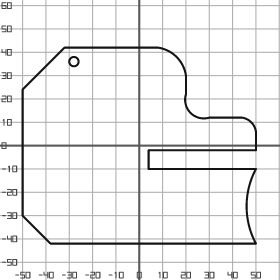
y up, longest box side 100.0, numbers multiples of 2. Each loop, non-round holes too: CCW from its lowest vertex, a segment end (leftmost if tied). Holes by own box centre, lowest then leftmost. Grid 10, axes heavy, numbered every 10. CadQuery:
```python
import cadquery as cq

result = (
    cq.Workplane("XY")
    .moveTo(-38.0, -42.0)
    .lineTo(50.0, -42.0)
    .threePointArc((46.0, -26.0), (50.0, -10.0))
    .lineTo(4.0, -10.0)
    .lineTo(4.0, -2.0)
    .lineTo(50.0, -2.0)
    .lineTo(50.0, 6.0)
    .threePointArc((48.0, 10.0), (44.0, 12.0))
    .lineTo(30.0, 12.0)
    .threePointArc((22.0, 14.0), (20.0, 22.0))
    .lineTo(20.0, 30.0)
    .threePointArc((16.0, 38.0), (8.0, 42.0))
    .lineTo(-32.0, 42.0)
    .lineTo(-50.0, 24.0)
    .lineTo(-50.0, -30.0)
    .close()
    .moveTo(-28.0, 36.0)
    .circle(2.0)
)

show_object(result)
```